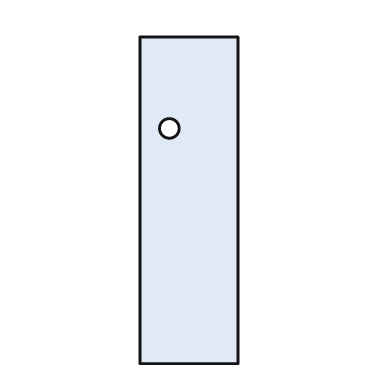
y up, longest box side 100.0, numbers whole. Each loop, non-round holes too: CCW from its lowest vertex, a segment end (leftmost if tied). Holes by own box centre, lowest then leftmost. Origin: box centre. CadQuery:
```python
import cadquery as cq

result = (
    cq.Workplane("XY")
    .moveTo(-15.0, -50.0)
    .lineTo(15.0, -50.0)
    .lineTo(15.0, 50.0)
    .lineTo(-15.0, 50.0)
    .close()
    .moveTo(-6.0, 22.0)
    .circle(3.0)
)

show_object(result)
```